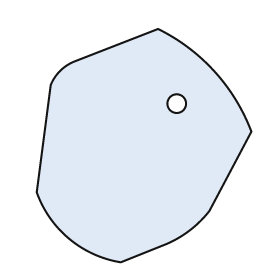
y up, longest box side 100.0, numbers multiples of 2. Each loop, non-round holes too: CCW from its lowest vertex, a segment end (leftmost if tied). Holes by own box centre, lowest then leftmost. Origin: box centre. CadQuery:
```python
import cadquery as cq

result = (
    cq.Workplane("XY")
    .moveTo(-10.0, -50.0)
    .lineTo(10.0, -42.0)
    .threePointArc((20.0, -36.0), (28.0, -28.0))
    .lineTo(46.0, 6.0)
    .threePointArc((30.0, 32.0), (6.0, 50.0))
    .lineTo(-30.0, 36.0)
    .threePointArc((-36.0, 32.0), (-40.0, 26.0))
    .lineTo(-46.0, -20.0)
    .threePointArc((-32.0, -40.0), (-10.0, -50.0))
    .close()
    .moveTo(14.0, 18.0)
    .circle(4.0)
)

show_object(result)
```